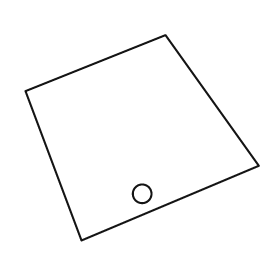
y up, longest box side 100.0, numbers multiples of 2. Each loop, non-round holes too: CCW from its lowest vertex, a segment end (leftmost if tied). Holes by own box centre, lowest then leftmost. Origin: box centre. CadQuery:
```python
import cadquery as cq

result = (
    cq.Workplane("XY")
    .moveTo(-26.0, -44.0)
    .lineTo(50.0, -12.0)
    .lineTo(10.0, 44.0)
    .lineTo(-50.0, 20.0)
    .close()
    .moveTo(0.0, -24.0)
    .circle(4.0)
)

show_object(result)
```